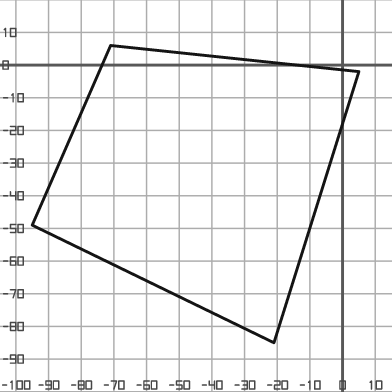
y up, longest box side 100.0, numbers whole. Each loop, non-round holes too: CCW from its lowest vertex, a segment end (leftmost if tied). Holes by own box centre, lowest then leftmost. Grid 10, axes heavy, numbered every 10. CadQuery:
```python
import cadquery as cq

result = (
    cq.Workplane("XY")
    .moveTo(-21.0, -85.0)
    .lineTo(5.0, -2.0)
    .lineTo(-71.0, 6.0)
    .lineTo(-95.0, -49.0)
    .close()
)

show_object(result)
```